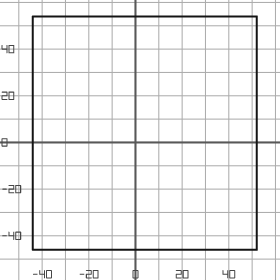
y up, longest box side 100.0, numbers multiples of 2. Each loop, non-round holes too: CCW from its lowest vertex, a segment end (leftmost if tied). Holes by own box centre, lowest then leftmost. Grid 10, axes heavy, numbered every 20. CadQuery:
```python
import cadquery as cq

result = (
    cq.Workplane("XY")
    .moveTo(-44.0, -46.0)
    .lineTo(52.0, -46.0)
    .lineTo(52.0, 54.0)
    .lineTo(-44.0, 54.0)
    .close()
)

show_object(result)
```